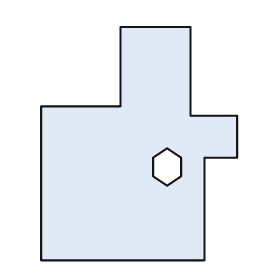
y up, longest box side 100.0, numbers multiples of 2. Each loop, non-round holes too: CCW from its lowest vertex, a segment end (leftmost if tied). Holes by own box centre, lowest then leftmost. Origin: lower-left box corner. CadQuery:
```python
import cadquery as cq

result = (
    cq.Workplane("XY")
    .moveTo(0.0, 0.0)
    .lineTo(70.0, 0.0)
    .lineTo(70.0, 44.0)
    .lineTo(84.0, 44.0)
    .lineTo(84.0, 62.0)
    .lineTo(64.0, 62.0)
    .lineTo(64.0, 100.0)
    .lineTo(34.0, 100.0)
    .lineTo(34.0, 66.0)
    .lineTo(0.0, 66.0)
    .close()
    .moveTo(54.0, 32.0)
    .lineTo(60.0, 36.0)
    .lineTo(60.0, 44.0)
    .lineTo(54.0, 48.0)
    .lineTo(48.0, 44.0)
    .lineTo(48.0, 36.0)
    .close()
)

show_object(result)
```